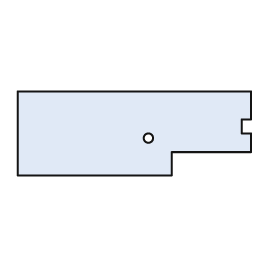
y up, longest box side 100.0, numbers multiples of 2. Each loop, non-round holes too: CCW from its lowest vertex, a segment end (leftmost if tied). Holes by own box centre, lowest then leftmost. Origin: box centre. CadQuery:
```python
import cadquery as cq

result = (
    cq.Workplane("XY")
    .moveTo(-50.0, -18.0)
    .lineTo(16.0, -18.0)
    .lineTo(16.0, -8.0)
    .lineTo(50.0, -8.0)
    .lineTo(50.0, 0.0)
    .lineTo(46.0, 0.0)
    .lineTo(46.0, 6.0)
    .lineTo(50.0, 6.0)
    .lineTo(50.0, 18.0)
    .lineTo(-50.0, 18.0)
    .close()
    .moveTo(6.0, -2.0)
    .circle(2.0)
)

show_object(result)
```